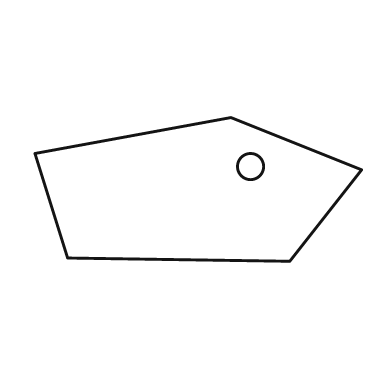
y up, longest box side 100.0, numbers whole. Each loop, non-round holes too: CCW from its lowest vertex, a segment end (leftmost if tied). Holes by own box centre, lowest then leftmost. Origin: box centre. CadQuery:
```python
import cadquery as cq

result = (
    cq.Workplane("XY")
    .moveTo(28.0, -22.0)
    .lineTo(50.0, 6.0)
    .lineTo(10.0, 22.0)
    .lineTo(-50.0, 11.0)
    .lineTo(-40.0, -21.0)
    .close()
    .moveTo(16.0, 7.0)
    .circle(4.0)
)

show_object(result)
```